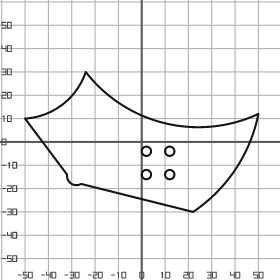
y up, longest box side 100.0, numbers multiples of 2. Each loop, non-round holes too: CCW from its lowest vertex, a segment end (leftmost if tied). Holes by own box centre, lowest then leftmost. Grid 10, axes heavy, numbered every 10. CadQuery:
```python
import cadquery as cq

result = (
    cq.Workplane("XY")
    .moveTo(22.0, -30.0)
    .threePointArc((40.0, -12.0), (50.0, 12.0))
    .threePointArc((10.0, 8.0), (-24.0, 30.0))
    .threePointArc((-34.0, 16.0), (-50.0, 10.0))
    .lineTo(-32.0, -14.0)
    .threePointArc((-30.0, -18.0), (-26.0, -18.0))
    .close()
    .moveTo(2.0, -14.0)
    .circle(2.0)
    .moveTo(12.0, -14.0)
    .circle(2.0)
    .moveTo(2.0, -4.0)
    .circle(2.0)
    .moveTo(12.0, -4.0)
    .circle(2.0)
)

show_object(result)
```